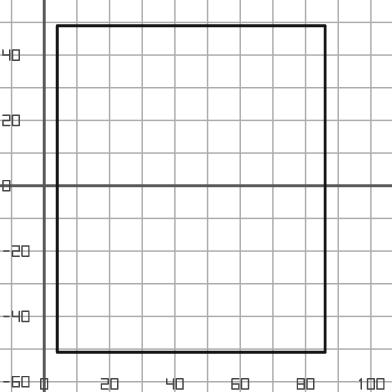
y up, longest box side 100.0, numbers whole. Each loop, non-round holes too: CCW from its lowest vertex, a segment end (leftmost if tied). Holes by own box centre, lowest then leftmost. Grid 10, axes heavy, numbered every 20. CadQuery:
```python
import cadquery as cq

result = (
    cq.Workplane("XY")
    .moveTo(4.0, -51.0)
    .lineTo(86.0, -51.0)
    .lineTo(86.0, 49.0)
    .lineTo(4.0, 49.0)
    .close()
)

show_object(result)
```